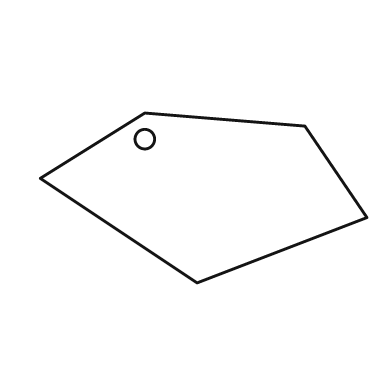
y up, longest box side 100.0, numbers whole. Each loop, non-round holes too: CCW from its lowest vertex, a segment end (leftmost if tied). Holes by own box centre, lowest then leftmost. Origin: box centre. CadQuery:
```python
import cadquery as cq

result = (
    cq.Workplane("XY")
    .moveTo(-2.0, -26.0)
    .lineTo(50.0, -6.0)
    .lineTo(31.0, 22.0)
    .lineTo(-18.0, 26.0)
    .lineTo(-50.0, 6.0)
    .close()
    .moveTo(-18.0, 18.0)
    .circle(3.0)
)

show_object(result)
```